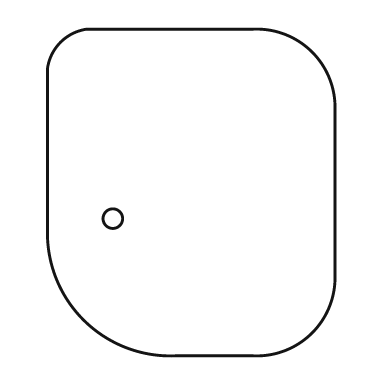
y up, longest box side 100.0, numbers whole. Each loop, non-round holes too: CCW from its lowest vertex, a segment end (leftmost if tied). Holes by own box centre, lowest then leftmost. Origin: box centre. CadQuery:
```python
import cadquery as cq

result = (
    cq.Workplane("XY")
    .moveTo(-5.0, -50.0)
    .lineTo(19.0, -50.0)
    .threePointArc((37.0, -43.0), (44.0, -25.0))
    .lineTo(44.0, 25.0)
    .threePointArc((37.0, 43.0), (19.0, 50.0))
    .lineTo(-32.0, 50.0)
    .threePointArc((-40.0, 46.0), (-44.0, 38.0))
    .lineTo(-44.0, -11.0)
    .threePointArc((-33.0, -39.0), (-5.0, -50.0))
    .close()
    .moveTo(-24.0, -8.0)
    .circle(3.0)
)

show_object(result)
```